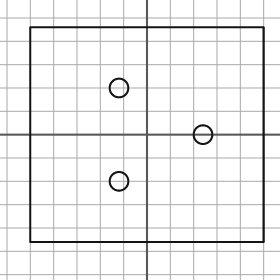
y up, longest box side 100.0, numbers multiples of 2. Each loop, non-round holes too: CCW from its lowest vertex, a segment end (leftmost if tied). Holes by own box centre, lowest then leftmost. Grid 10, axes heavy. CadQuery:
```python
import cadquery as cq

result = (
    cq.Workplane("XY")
    .moveTo(-50.0, -46.0)
    .lineTo(50.0, -46.0)
    .lineTo(50.0, 46.0)
    .lineTo(-50.0, 46.0)
    .close()
    .moveTo(-12.0, -20.0)
    .circle(4.0)
    .moveTo(24.0, 0.0)
    .circle(4.0)
    .moveTo(-12.0, 20.0)
    .circle(4.0)
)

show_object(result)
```